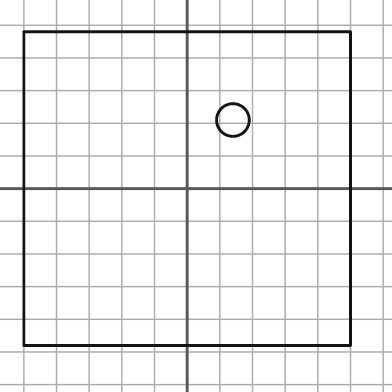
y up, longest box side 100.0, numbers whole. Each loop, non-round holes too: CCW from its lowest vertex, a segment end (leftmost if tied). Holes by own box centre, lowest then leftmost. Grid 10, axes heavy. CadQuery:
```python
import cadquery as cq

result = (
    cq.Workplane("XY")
    .moveTo(-50.0, -48.0)
    .lineTo(50.0, -48.0)
    .lineTo(50.0, 48.0)
    .lineTo(-50.0, 48.0)
    .close()
    .moveTo(14.0, 21.0)
    .circle(5.0)
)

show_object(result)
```